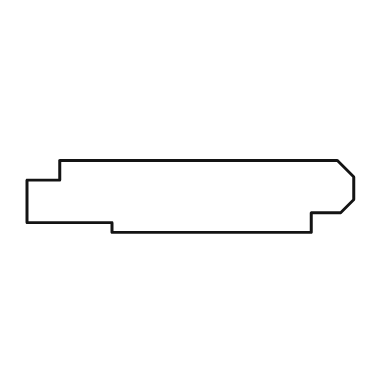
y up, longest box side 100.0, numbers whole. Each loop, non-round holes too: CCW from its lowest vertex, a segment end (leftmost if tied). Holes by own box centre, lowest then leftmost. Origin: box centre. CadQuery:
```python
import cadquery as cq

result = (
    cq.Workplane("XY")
    .moveTo(-24.0, -11.0)
    .lineTo(37.0, -11.0)
    .lineTo(37.0, -5.0)
    .lineTo(46.0, -5.0)
    .lineTo(50.0, -1.0)
    .lineTo(50.0, 6.0)
    .lineTo(45.0, 11.0)
    .lineTo(-40.0, 11.0)
    .lineTo(-40.0, 5.0)
    .lineTo(-50.0, 5.0)
    .lineTo(-50.0, -8.0)
    .lineTo(-24.0, -8.0)
    .close()
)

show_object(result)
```